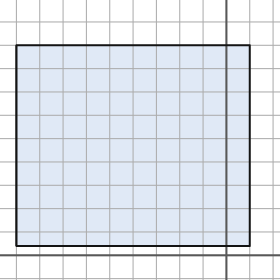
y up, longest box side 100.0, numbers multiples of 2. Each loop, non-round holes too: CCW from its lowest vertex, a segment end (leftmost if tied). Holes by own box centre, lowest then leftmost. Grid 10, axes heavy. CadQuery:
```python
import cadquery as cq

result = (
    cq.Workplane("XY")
    .moveTo(-90.0, 4.0)
    .lineTo(10.0, 4.0)
    .lineTo(10.0, 90.0)
    .lineTo(-90.0, 90.0)
    .close()
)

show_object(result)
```